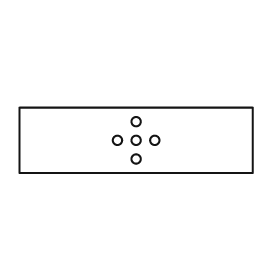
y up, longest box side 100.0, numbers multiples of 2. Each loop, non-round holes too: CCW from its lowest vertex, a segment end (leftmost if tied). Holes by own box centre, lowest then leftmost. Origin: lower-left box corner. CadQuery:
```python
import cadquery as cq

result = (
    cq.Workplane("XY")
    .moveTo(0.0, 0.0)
    .lineTo(100.0, 0.0)
    .lineTo(100.0, 28.0)
    .lineTo(0.0, 28.0)
    .close()
    .moveTo(50.0, 6.0)
    .circle(2.0)
    .moveTo(42.0, 14.0)
    .circle(2.0)
    .moveTo(50.0, 14.0)
    .circle(2.0)
    .moveTo(58.0, 14.0)
    .circle(2.0)
    .moveTo(50.0, 22.0)
    .circle(2.0)
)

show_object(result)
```